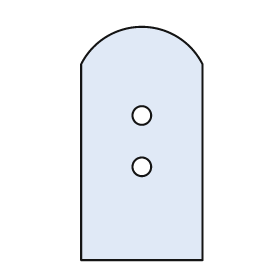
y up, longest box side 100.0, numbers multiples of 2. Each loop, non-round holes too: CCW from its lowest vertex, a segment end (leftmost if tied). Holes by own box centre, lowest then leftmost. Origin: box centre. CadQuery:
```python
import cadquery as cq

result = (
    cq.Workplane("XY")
    .moveTo(-26.0, -50.0)
    .lineTo(26.0, -50.0)
    .lineTo(26.0, 34.0)
    .threePointArc((0.0, 50.0), (-26.0, 34.0))
    .close()
    .moveTo(0.0, -10.0)
    .circle(4.0)
    .moveTo(0.0, 12.0)
    .circle(4.0)
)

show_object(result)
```